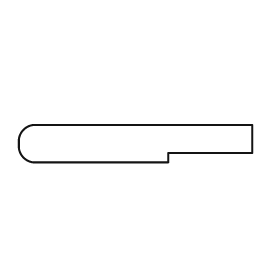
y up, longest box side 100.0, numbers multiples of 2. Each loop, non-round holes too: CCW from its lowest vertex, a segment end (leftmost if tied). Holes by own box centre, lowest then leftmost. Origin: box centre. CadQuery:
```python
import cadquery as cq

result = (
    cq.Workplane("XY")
    .moveTo(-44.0, -8.0)
    .lineTo(14.0, -8.0)
    .lineTo(14.0, -4.0)
    .lineTo(50.0, -4.0)
    .lineTo(50.0, 8.0)
    .lineTo(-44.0, 8.0)
    .threePointArc((-48.0, 6.0), (-50.0, 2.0))
    .lineTo(-50.0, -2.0)
    .threePointArc((-48.0, -6.0), (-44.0, -8.0))
    .close()
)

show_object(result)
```